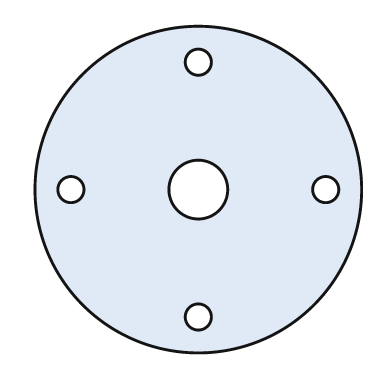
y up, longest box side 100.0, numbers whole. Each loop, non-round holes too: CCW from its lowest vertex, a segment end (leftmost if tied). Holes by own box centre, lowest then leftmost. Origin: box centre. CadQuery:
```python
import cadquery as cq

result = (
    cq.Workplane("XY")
    .moveTo(0.0, 0.0)
    .circle(50.0)
    .moveTo(0.0, -39.0)
    .circle(4.0)
    .moveTo(-39.0, 0.0)
    .circle(4.0)
    .moveTo(0.0, 0.0)
    .circle(9.0)
    .moveTo(39.0, 0.0)
    .circle(4.0)
    .moveTo(0.0, 39.0)
    .circle(4.0)
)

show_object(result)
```